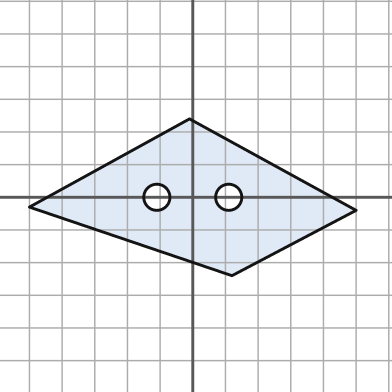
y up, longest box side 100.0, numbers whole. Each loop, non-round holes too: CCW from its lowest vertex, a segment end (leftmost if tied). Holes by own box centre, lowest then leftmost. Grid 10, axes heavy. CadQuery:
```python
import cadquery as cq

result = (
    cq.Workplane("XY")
    .moveTo(12.0, -24.0)
    .lineTo(50.0, -4.0)
    .lineTo(-1.0, 24.0)
    .lineTo(-50.0, -3.0)
    .close()
    .moveTo(-11.0, 0.0)
    .circle(4.0)
    .moveTo(11.0, 0.0)
    .circle(4.0)
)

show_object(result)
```